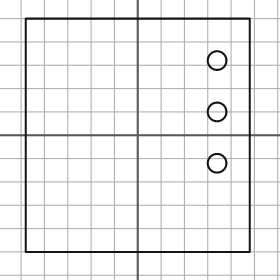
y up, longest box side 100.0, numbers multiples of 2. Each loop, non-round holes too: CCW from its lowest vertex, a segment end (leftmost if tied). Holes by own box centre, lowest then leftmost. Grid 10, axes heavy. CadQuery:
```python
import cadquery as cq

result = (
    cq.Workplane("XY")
    .moveTo(-48.0, -50.0)
    .lineTo(48.0, -50.0)
    .lineTo(48.0, 50.0)
    .lineTo(-48.0, 50.0)
    .close()
    .moveTo(34.0, -12.0)
    .circle(4.0)
    .moveTo(34.0, 10.0)
    .circle(4.0)
    .moveTo(34.0, 32.0)
    .circle(4.0)
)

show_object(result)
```